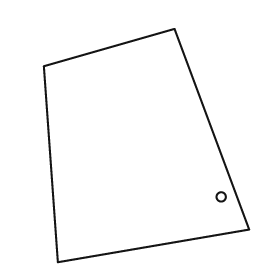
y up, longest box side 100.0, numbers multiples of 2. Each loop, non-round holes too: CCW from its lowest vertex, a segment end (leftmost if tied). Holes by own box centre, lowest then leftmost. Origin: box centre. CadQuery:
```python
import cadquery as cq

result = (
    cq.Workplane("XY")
    .moveTo(-38.0, -50.0)
    .lineTo(44.0, -36.0)
    .lineTo(12.0, 50.0)
    .lineTo(-44.0, 34.0)
    .close()
    .moveTo(32.0, -22.0)
    .circle(2.0)
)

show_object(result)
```